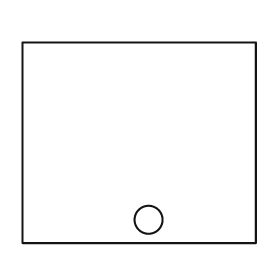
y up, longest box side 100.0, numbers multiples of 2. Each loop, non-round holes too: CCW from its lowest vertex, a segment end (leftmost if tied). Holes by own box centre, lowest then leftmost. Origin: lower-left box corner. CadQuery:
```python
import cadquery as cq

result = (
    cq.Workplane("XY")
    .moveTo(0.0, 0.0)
    .lineTo(100.0, 0.0)
    .lineTo(100.0, 86.0)
    .lineTo(0.0, 86.0)
    .close()
    .moveTo(54.0, 10.0)
    .circle(6.0)
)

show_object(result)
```